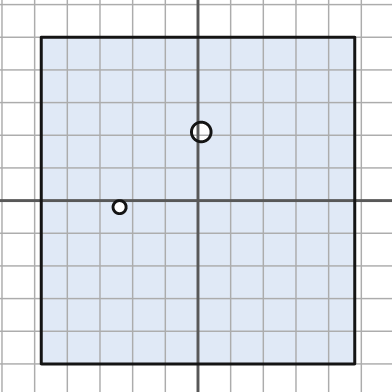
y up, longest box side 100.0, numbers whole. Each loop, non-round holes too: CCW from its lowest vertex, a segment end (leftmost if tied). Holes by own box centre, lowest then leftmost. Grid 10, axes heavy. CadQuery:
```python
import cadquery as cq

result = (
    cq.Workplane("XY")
    .moveTo(-48.0, -50.0)
    .lineTo(48.0, -50.0)
    .lineTo(48.0, 50.0)
    .lineTo(-48.0, 50.0)
    .close()
    .moveTo(-24.0, -2.0)
    .circle(2.0)
    .moveTo(1.0, 21.0)
    .circle(3.0)
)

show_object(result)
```